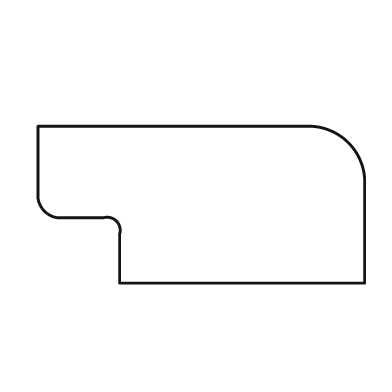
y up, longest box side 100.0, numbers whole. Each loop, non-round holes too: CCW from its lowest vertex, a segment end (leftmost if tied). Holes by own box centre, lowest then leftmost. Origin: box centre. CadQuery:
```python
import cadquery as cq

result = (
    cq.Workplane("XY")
    .moveTo(-25.0, -24.0)
    .lineTo(50.0, -24.0)
    .lineTo(50.0, 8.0)
    .threePointArc((45.0, 19.0), (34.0, 24.0))
    .lineTo(-50.0, 24.0)
    .lineTo(-50.0, 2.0)
    .threePointArc((-48.0, -2.0), (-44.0, -4.0))
    .lineTo(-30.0, -4.0)
    .threePointArc((-26.0, -5.0), (-25.0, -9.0))
    .close()
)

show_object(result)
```